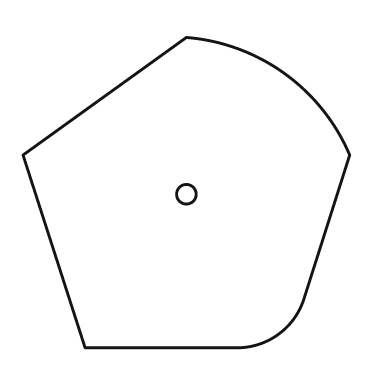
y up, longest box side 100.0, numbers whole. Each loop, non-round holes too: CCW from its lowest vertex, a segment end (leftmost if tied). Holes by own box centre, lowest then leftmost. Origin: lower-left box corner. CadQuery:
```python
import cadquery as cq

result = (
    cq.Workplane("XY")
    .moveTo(19.0, 0.0)
    .lineTo(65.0, 0.0)
    .threePointArc((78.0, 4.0), (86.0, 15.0))
    .lineTo(100.0, 59.0)
    .threePointArc((80.0, 84.0), (50.0, 95.0))
    .lineTo(0.0, 59.0)
    .close()
    .moveTo(50.0, 47.0)
    .circle(3.0)
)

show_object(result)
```